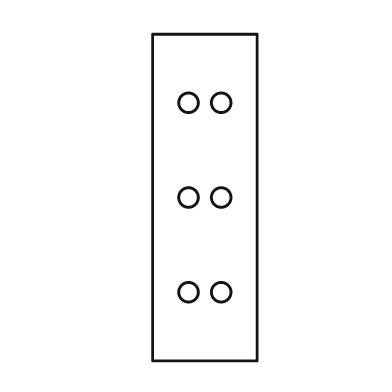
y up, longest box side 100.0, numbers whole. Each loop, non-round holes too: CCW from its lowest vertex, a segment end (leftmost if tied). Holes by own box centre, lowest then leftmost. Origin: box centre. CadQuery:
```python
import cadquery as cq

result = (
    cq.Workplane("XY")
    .moveTo(-16.0, -50.0)
    .lineTo(16.0, -50.0)
    .lineTo(16.0, 50.0)
    .lineTo(-16.0, 50.0)
    .close()
    .moveTo(-5.0, -29.0)
    .circle(3.0)
    .moveTo(5.0, -29.0)
    .circle(3.0)
    .moveTo(-5.0, 0.0)
    .circle(3.0)
    .moveTo(5.0, 0.0)
    .circle(3.0)
    .moveTo(-5.0, 29.0)
    .circle(3.0)
    .moveTo(5.0, 29.0)
    .circle(3.0)
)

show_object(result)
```